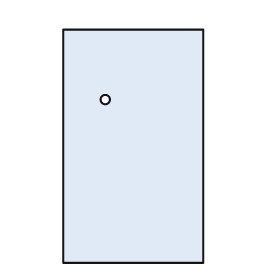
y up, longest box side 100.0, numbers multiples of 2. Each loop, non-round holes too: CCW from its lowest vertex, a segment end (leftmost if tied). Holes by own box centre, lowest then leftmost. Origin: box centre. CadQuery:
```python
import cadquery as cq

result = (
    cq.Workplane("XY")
    .moveTo(-30.0, -50.0)
    .lineTo(30.0, -50.0)
    .lineTo(30.0, 50.0)
    .lineTo(-30.0, 50.0)
    .close()
    .moveTo(-12.0, 20.0)
    .circle(2.0)
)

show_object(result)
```